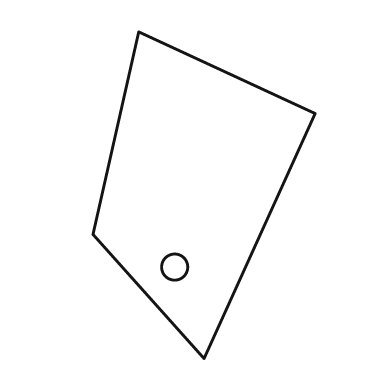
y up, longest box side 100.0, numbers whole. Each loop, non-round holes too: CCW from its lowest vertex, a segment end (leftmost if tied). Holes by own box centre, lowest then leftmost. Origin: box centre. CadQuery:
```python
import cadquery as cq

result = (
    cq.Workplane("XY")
    .moveTo(0.0, -50.0)
    .lineTo(34.0, 25.0)
    .lineTo(-20.0, 50.0)
    .lineTo(-34.0, -12.0)
    .close()
    .moveTo(-9.0, -22.0)
    .circle(4.0)
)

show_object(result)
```